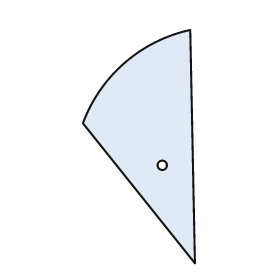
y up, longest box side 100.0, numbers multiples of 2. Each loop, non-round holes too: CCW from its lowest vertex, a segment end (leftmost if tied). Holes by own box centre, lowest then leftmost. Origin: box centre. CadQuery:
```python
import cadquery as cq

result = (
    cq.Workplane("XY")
    .moveTo(24.0, -50.0)
    .lineTo(22.0, 50.0)
    .threePointArc((-6.0, 36.0), (-24.0, 10.0))
    .close()
    .moveTo(10.0, -8.0)
    .circle(2.0)
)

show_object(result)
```